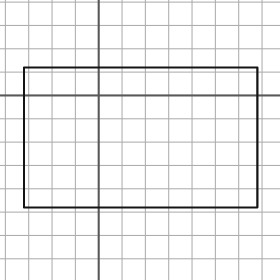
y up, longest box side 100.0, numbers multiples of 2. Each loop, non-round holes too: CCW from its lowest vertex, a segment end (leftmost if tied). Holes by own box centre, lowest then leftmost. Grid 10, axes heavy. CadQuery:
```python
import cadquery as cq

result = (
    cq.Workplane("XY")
    .moveTo(-32.0, -48.0)
    .lineTo(68.0, -48.0)
    .lineTo(68.0, 12.0)
    .lineTo(-32.0, 12.0)
    .close()
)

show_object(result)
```